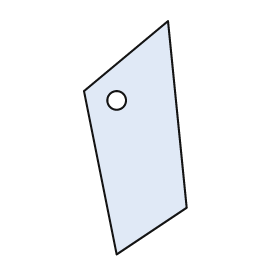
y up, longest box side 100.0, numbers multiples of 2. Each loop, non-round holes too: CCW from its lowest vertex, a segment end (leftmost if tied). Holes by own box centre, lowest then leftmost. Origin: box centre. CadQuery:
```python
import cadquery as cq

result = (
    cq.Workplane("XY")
    .moveTo(-8.0, -50.0)
    .lineTo(22.0, -30.0)
    .lineTo(14.0, 50.0)
    .lineTo(-22.0, 20.0)
    .close()
    .moveTo(-8.0, 16.0)
    .circle(4.0)
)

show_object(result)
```